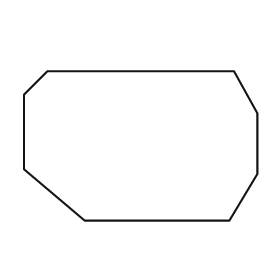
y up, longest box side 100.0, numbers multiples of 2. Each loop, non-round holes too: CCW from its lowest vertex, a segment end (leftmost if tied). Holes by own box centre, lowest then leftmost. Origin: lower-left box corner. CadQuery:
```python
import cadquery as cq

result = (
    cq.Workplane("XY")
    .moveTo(26.0, 0.0)
    .lineTo(88.0, 0.0)
    .lineTo(100.0, 20.0)
    .lineTo(100.0, 46.0)
    .lineTo(90.0, 64.0)
    .lineTo(10.0, 64.0)
    .lineTo(0.0, 54.0)
    .lineTo(0.0, 22.0)
    .close()
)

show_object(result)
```